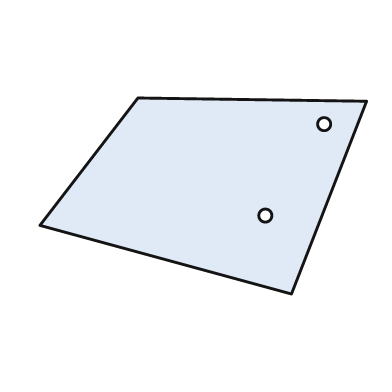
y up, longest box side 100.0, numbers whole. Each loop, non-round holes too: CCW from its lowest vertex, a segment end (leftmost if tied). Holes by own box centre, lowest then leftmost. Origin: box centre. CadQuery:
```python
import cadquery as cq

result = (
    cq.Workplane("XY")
    .moveTo(27.0, -30.0)
    .lineTo(50.0, 29.0)
    .lineTo(-20.0, 30.0)
    .lineTo(-50.0, -9.0)
    .close()
    .moveTo(19.0, -6.0)
    .circle(2.0)
    .moveTo(37.0, 22.0)
    .circle(2.0)
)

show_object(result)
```